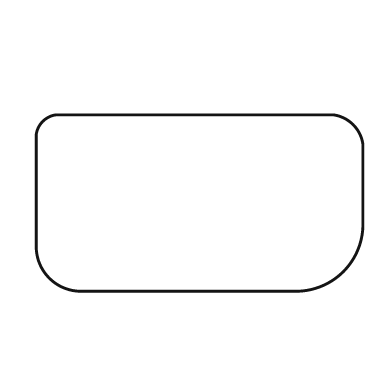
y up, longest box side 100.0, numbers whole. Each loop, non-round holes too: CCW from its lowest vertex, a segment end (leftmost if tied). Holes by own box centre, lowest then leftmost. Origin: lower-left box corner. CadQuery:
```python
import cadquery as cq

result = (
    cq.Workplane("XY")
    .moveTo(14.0, 0.0)
    .lineTo(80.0, 0.0)
    .threePointArc((94.0, 6.0), (100.0, 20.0))
    .lineTo(100.0, 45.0)
    .threePointArc((97.0, 51.0), (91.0, 54.0))
    .lineTo(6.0, 54.0)
    .threePointArc((2.0, 52.0), (0.0, 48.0))
    .lineTo(0.0, 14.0)
    .threePointArc((4.0, 4.0), (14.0, 0.0))
    .close()
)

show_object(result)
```